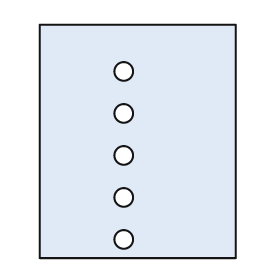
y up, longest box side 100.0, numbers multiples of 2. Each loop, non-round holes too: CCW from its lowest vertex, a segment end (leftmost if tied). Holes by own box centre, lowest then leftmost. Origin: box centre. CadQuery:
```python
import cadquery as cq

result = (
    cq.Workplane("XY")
    .moveTo(-42.0, -50.0)
    .lineTo(42.0, -50.0)
    .lineTo(42.0, 50.0)
    .lineTo(-42.0, 50.0)
    .close()
    .moveTo(-6.0, -42.0)
    .circle(4.0)
    .moveTo(-6.0, -24.0)
    .circle(4.0)
    .moveTo(-6.0, -6.0)
    .circle(4.0)
    .moveTo(-6.0, 12.0)
    .circle(4.0)
    .moveTo(-6.0, 30.0)
    .circle(4.0)
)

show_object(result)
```